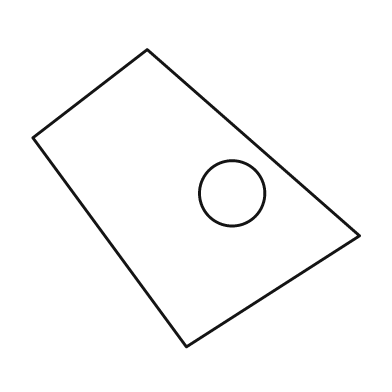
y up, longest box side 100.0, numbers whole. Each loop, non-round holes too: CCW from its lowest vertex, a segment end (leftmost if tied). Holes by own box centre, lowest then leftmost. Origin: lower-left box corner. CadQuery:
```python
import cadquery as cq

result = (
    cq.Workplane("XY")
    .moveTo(47.0, 0.0)
    .lineTo(100.0, 34.0)
    .lineTo(35.0, 91.0)
    .lineTo(0.0, 64.0)
    .close()
    .moveTo(61.0, 47.0)
    .circle(10.0)
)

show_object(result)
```